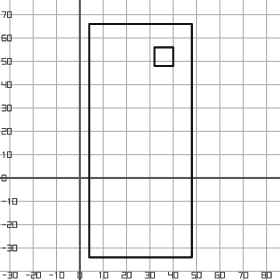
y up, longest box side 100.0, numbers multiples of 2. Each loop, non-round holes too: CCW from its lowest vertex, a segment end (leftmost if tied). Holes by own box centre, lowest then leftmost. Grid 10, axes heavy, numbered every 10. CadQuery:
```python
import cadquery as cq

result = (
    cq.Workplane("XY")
    .moveTo(4.0, -34.0)
    .lineTo(48.0, -34.0)
    .lineTo(48.0, 66.0)
    .lineTo(4.0, 66.0)
    .close()
    .moveTo(32.0, 48.0)
    .lineTo(40.0, 48.0)
    .lineTo(40.0, 56.0)
    .lineTo(32.0, 56.0)
    .close()
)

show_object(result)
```